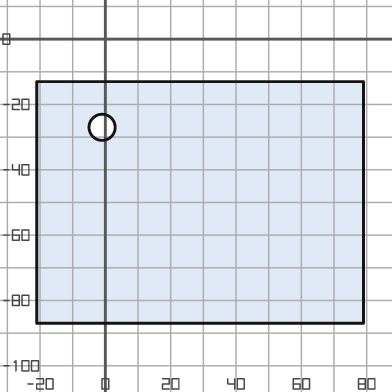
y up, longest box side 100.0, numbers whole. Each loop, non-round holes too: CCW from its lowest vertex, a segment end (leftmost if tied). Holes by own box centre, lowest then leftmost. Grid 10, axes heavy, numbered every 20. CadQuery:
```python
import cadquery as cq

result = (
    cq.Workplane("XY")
    .moveTo(-21.0, -87.0)
    .lineTo(79.0, -87.0)
    .lineTo(79.0, -13.0)
    .lineTo(-21.0, -13.0)
    .close()
    .moveTo(-1.0, -27.0)
    .circle(4.0)
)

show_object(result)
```